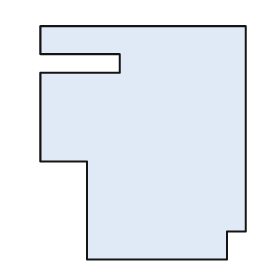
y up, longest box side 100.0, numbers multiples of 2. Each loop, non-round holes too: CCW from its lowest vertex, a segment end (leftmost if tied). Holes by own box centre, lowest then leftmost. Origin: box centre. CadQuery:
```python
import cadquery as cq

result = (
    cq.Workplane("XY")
    .moveTo(-24.0, -50.0)
    .lineTo(36.0, -50.0)
    .lineTo(36.0, -38.0)
    .lineTo(44.0, -38.0)
    .lineTo(44.0, 50.0)
    .lineTo(-44.0, 50.0)
    .lineTo(-44.0, 38.0)
    .lineTo(-10.0, 38.0)
    .lineTo(-10.0, 30.0)
    .lineTo(-44.0, 30.0)
    .lineTo(-44.0, -8.0)
    .lineTo(-24.0, -8.0)
    .close()
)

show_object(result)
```